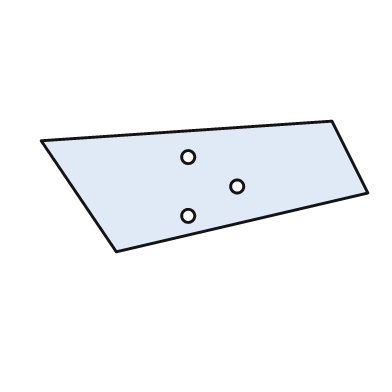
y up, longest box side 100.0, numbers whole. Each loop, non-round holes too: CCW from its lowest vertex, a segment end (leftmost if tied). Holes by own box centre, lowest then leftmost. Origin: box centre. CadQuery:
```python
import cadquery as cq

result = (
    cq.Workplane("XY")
    .moveTo(-27.0, -20.0)
    .lineTo(50.0, -2.0)
    .lineTo(39.0, 20.0)
    .lineTo(-50.0, 14.0)
    .close()
    .moveTo(-5.0, -9.0)
    .circle(2.0)
    .moveTo(10.0, 0.0)
    .circle(2.0)
    .moveTo(-5.0, 9.0)
    .circle(2.0)
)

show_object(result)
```